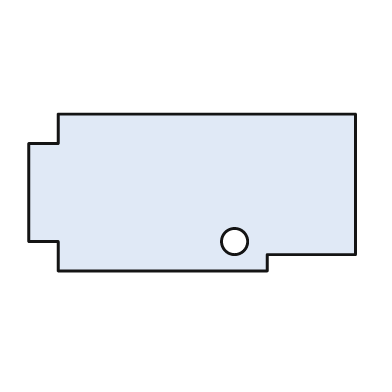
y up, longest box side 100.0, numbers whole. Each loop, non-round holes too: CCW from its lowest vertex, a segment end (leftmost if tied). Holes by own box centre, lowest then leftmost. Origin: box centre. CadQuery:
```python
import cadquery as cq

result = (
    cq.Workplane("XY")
    .moveTo(-41.0, -24.0)
    .lineTo(23.0, -24.0)
    .lineTo(23.0, -19.0)
    .lineTo(50.0, -19.0)
    .lineTo(50.0, 24.0)
    .lineTo(-41.0, 24.0)
    .lineTo(-41.0, 15.0)
    .lineTo(-50.0, 15.0)
    .lineTo(-50.0, -15.0)
    .lineTo(-41.0, -15.0)
    .close()
    .moveTo(13.0, -15.0)
    .circle(4.0)
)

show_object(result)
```